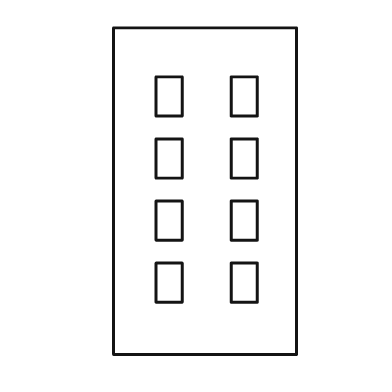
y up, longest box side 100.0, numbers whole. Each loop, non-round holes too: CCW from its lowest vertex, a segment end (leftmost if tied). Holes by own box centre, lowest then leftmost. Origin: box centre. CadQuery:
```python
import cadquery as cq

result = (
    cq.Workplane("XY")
    .moveTo(-28.0, -50.0)
    .lineTo(28.0, -50.0)
    .lineTo(28.0, 50.0)
    .lineTo(-28.0, 50.0)
    .close()
    .moveTo(-15.0, -34.0)
    .lineTo(-7.0, -34.0)
    .lineTo(-7.0, -22.0)
    .lineTo(-15.0, -22.0)
    .close()
    .moveTo(8.0, -34.0)
    .lineTo(16.0, -34.0)
    .lineTo(16.0, -22.0)
    .lineTo(8.0, -22.0)
    .close()
    .moveTo(-15.0, -15.0)
    .lineTo(-7.0, -15.0)
    .lineTo(-7.0, -3.0)
    .lineTo(-15.0, -3.0)
    .close()
    .moveTo(8.0, -15.0)
    .lineTo(16.0, -15.0)
    .lineTo(16.0, -3.0)
    .lineTo(8.0, -3.0)
    .close()
    .moveTo(-15.0, 4.0)
    .lineTo(-7.0, 4.0)
    .lineTo(-7.0, 16.0)
    .lineTo(-15.0, 16.0)
    .close()
    .moveTo(8.0, 4.0)
    .lineTo(16.0, 4.0)
    .lineTo(16.0, 16.0)
    .lineTo(8.0, 16.0)
    .close()
    .moveTo(-15.0, 23.0)
    .lineTo(-7.0, 23.0)
    .lineTo(-7.0, 35.0)
    .lineTo(-15.0, 35.0)
    .close()
    .moveTo(8.0, 23.0)
    .lineTo(16.0, 23.0)
    .lineTo(16.0, 35.0)
    .lineTo(8.0, 35.0)
    .close()
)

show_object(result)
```